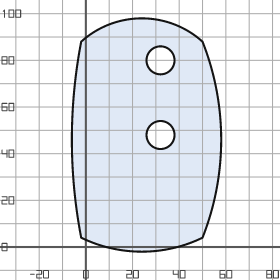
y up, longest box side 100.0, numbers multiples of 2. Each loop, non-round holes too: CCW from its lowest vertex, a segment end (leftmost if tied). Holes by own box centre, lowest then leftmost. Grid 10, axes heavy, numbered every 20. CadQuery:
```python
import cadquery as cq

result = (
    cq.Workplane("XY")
    .moveTo(-2.0, 4.0)
    .threePointArc((24.0, -2.0), (50.0, 4.0))
    .threePointArc((58.0, 46.0), (50.0, 88.0))
    .threePointArc((24.0, 98.0), (-2.0, 88.0))
    .threePointArc((-6.0, 46.0), (-2.0, 4.0))
    .close()
    .moveTo(32.0, 48.0)
    .circle(6.0)
    .moveTo(32.0, 80.0)
    .circle(6.0)
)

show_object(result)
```